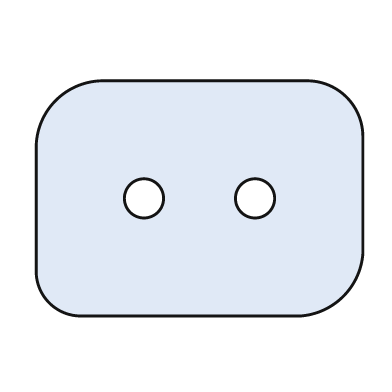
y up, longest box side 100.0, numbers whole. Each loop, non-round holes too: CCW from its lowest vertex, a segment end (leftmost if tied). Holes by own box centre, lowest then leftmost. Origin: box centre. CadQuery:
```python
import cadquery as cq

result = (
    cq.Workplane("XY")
    .moveTo(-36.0, -36.0)
    .lineTo(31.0, -36.0)
    .threePointArc((44.0, -30.0), (50.0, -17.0))
    .lineTo(50.0, 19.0)
    .threePointArc((45.0, 31.0), (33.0, 36.0))
    .lineTo(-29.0, 36.0)
    .threePointArc((-44.0, 30.0), (-50.0, 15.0))
    .lineTo(-50.0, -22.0)
    .threePointArc((-46.0, -32.0), (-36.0, -36.0))
    .close()
    .moveTo(-17.0, 0.0)
    .circle(6.0)
    .moveTo(17.0, 0.0)
    .circle(6.0)
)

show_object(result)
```